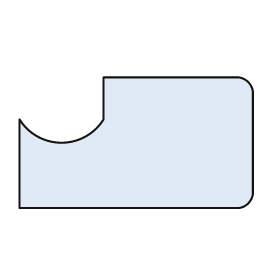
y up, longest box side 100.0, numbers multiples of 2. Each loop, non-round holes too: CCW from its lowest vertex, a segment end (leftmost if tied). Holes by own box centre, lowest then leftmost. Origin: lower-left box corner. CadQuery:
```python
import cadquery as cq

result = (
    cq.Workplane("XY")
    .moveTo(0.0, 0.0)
    .lineTo(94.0, 0.0)
    .threePointArc((98.0, 2.0), (100.0, 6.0))
    .lineTo(100.0, 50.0)
    .threePointArc((98.0, 54.0), (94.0, 56.0))
    .lineTo(36.0, 56.0)
    .lineTo(36.0, 38.0)
    .threePointArc((18.0, 28.0), (0.0, 38.0))
    .close()
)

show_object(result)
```